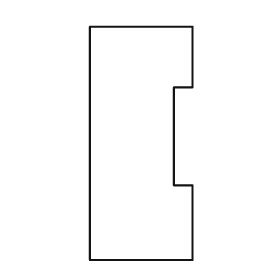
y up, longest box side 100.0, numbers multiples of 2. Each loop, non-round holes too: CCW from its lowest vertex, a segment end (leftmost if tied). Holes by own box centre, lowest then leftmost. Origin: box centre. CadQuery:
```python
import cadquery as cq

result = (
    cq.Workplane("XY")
    .moveTo(-22.0, -50.0)
    .lineTo(22.0, -50.0)
    .lineTo(22.0, -18.0)
    .lineTo(14.0, -18.0)
    .lineTo(14.0, 24.0)
    .lineTo(22.0, 24.0)
    .lineTo(22.0, 50.0)
    .lineTo(-22.0, 50.0)
    .close()
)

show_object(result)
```